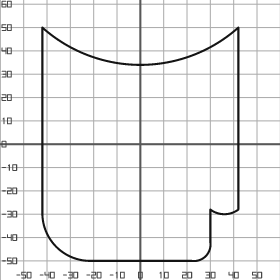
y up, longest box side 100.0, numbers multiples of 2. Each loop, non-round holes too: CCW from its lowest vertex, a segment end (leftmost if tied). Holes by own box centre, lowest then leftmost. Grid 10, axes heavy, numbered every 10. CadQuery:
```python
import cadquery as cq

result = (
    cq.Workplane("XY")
    .moveTo(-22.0, -50.0)
    .lineTo(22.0, -50.0)
    .threePointArc((28.0, -48.0), (30.0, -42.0))
    .lineTo(30.0, -28.0)
    .threePointArc((36.0, -30.0), (42.0, -28.0))
    .lineTo(42.0, 50.0)
    .threePointArc((0.0, 34.0), (-42.0, 50.0))
    .lineTo(-42.0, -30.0)
    .threePointArc((-36.0, -44.0), (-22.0, -50.0))
    .close()
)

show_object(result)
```